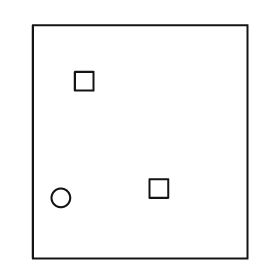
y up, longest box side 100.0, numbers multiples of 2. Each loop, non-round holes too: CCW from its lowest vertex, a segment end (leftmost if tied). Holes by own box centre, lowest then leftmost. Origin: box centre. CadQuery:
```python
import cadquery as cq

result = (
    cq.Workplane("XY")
    .moveTo(-46.0, -50.0)
    .lineTo(46.0, -50.0)
    .lineTo(46.0, 50.0)
    .lineTo(-46.0, 50.0)
    .close()
    .moveTo(-34.0, -24.0)
    .circle(4.0)
    .moveTo(4.0, -24.0)
    .lineTo(12.0, -24.0)
    .lineTo(12.0, -16.0)
    .lineTo(4.0, -16.0)
    .close()
    .moveTo(-28.0, 22.0)
    .lineTo(-20.0, 22.0)
    .lineTo(-20.0, 30.0)
    .lineTo(-28.0, 30.0)
    .close()
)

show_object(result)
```